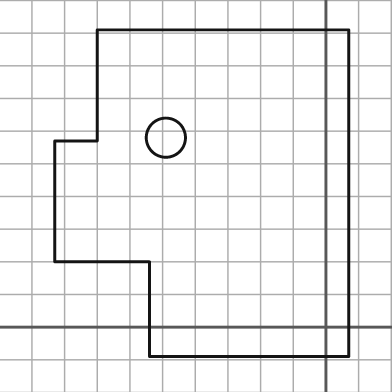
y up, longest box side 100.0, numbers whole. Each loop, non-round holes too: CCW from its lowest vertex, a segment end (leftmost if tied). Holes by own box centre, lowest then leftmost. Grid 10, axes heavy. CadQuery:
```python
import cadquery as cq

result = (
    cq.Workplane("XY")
    .moveTo(-54.0, -9.0)
    .lineTo(7.0, -9.0)
    .lineTo(7.0, 91.0)
    .lineTo(-70.0, 91.0)
    .lineTo(-70.0, 57.0)
    .lineTo(-83.0, 57.0)
    .lineTo(-83.0, 20.0)
    .lineTo(-54.0, 20.0)
    .close()
    .moveTo(-49.0, 58.0)
    .circle(6.0)
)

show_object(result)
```